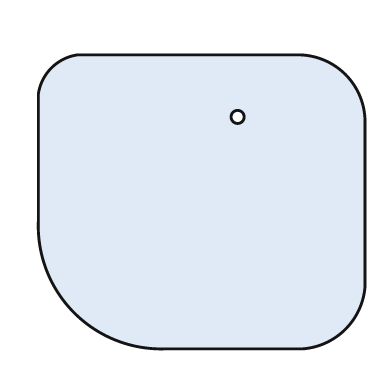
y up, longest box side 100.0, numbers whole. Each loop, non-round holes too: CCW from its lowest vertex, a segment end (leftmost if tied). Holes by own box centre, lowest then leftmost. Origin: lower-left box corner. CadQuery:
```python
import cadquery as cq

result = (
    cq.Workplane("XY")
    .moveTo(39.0, 0.0)
    .lineTo(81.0, 0.0)
    .threePointArc((94.0, 6.0), (100.0, 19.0))
    .lineTo(100.0, 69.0)
    .threePointArc((94.0, 84.0), (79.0, 90.0))
    .lineTo(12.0, 90.0)
    .threePointArc((4.0, 86.0), (0.0, 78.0))
    .lineTo(0.0, 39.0)
    .threePointArc((11.0, 11.0), (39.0, 0.0))
    .close()
    .moveTo(61.0, 71.0)
    .circle(2.0)
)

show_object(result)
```